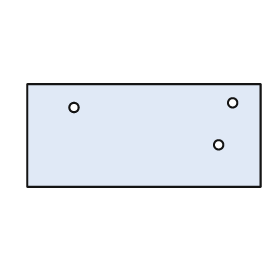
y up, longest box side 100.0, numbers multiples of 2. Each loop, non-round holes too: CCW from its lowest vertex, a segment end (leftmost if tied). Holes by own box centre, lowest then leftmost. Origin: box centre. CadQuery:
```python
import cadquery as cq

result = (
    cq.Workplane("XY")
    .moveTo(-50.0, -22.0)
    .lineTo(50.0, -22.0)
    .lineTo(50.0, 22.0)
    .lineTo(-50.0, 22.0)
    .close()
    .moveTo(32.0, -4.0)
    .circle(2.0)
    .moveTo(-30.0, 12.0)
    .circle(2.0)
    .moveTo(38.0, 14.0)
    .circle(2.0)
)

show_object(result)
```